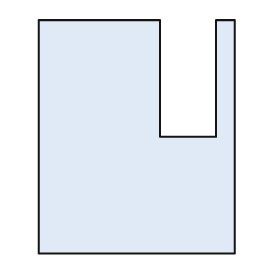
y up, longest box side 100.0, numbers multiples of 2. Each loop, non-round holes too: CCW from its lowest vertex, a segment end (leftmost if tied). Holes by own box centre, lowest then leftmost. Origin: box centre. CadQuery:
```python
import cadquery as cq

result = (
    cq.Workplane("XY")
    .moveTo(-42.0, -50.0)
    .lineTo(42.0, -50.0)
    .lineTo(42.0, 50.0)
    .lineTo(34.0, 50.0)
    .lineTo(34.0, 0.0)
    .lineTo(10.0, 0.0)
    .lineTo(10.0, 50.0)
    .lineTo(-42.0, 50.0)
    .close()
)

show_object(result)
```